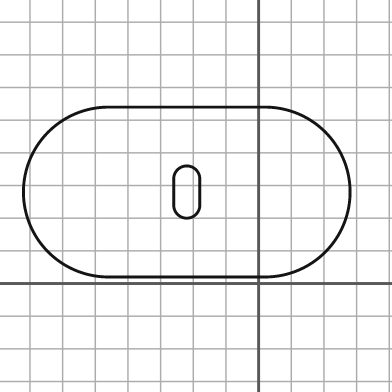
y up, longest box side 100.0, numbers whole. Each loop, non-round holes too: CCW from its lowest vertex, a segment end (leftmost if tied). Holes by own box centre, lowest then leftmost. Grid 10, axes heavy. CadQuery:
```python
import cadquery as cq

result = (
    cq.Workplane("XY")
    .moveTo(-46.0, 2.0)
    .lineTo(2.0, 2.0)
    .threePointArc((28.0, 28.0), (2.0, 54.0))
    .lineTo(-46.0, 54.0)
    .threePointArc((-72.0, 28.0), (-46.0, 2.0))
    .close()
    .moveTo(-26.0, 24.0)
    .threePointArc((-22.0, 20.0), (-18.0, 24.0))
    .lineTo(-18.0, 32.0)
    .threePointArc((-22.0, 36.0), (-26.0, 32.0))
    .close()
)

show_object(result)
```